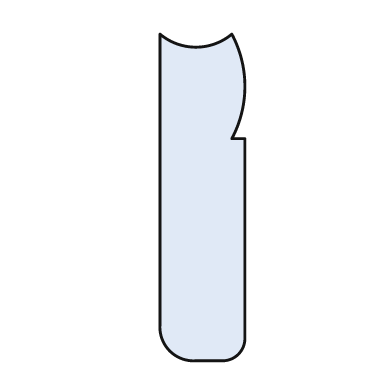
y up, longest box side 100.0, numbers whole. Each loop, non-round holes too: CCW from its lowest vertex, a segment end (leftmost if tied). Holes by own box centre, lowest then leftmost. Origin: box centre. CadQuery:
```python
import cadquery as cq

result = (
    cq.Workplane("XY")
    .moveTo(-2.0, -50.0)
    .lineTo(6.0, -50.0)
    .threePointArc((11.0, -48.0), (13.0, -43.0))
    .lineTo(13.0, 18.0)
    .lineTo(9.0, 18.0)
    .threePointArc((13.0, 34.0), (9.0, 50.0))
    .threePointArc((-2.0, 46.0), (-13.0, 50.0))
    .lineTo(-13.0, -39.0)
    .threePointArc((-10.0, -47.0), (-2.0, -50.0))
    .close()
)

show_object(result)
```